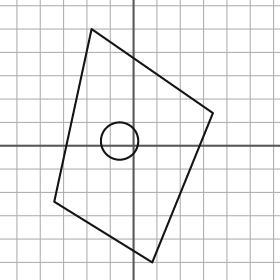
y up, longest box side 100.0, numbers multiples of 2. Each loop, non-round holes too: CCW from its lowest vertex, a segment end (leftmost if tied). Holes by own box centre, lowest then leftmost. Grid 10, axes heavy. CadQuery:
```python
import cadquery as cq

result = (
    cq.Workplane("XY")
    .moveTo(8.0, -50.0)
    .lineTo(34.0, 14.0)
    .lineTo(-18.0, 50.0)
    .lineTo(-34.0, -24.0)
    .close()
    .moveTo(-6.0, 2.0)
    .circle(8.0)
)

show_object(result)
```